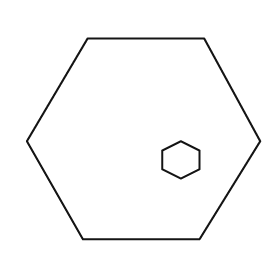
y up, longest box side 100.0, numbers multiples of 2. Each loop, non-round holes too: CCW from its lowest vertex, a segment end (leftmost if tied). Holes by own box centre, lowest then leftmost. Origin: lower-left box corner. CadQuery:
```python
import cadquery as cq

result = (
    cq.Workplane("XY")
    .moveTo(24.0, 0.0)
    .lineTo(74.0, 0.0)
    .lineTo(100.0, 42.0)
    .lineTo(76.0, 86.0)
    .lineTo(26.0, 86.0)
    .lineTo(0.0, 42.0)
    .close()
    .moveTo(66.0, 26.0)
    .lineTo(74.0, 30.0)
    .lineTo(74.0, 38.0)
    .lineTo(66.0, 42.0)
    .lineTo(58.0, 38.0)
    .lineTo(58.0, 30.0)
    .close()
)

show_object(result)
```